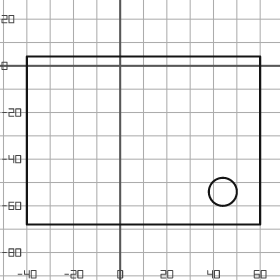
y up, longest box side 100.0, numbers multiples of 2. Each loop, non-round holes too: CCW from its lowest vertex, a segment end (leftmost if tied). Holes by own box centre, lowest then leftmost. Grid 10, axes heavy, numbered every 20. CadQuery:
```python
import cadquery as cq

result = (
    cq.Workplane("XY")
    .moveTo(-40.0, -68.0)
    .lineTo(60.0, -68.0)
    .lineTo(60.0, 4.0)
    .lineTo(-40.0, 4.0)
    .close()
    .moveTo(44.0, -54.0)
    .circle(6.0)
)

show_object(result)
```